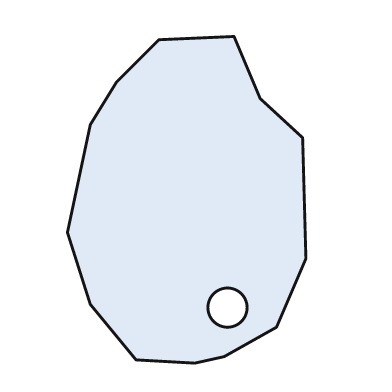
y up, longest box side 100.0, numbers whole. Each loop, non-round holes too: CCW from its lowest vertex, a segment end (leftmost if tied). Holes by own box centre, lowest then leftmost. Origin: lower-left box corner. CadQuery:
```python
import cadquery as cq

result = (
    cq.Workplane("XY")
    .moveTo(39.0, 0.0)
    .lineTo(48.0, 2.0)
    .lineTo(64.0, 11.0)
    .lineTo(73.0, 32.0)
    .lineTo(72.0, 69.0)
    .lineTo(59.0, 81.0)
    .lineTo(51.0, 100.0)
    .lineTo(28.0, 99.0)
    .lineTo(15.0, 86.0)
    .lineTo(7.0, 73.0)
    .lineTo(0.0, 40.0)
    .lineTo(7.0, 18.0)
    .lineTo(21.0, 1.0)
    .close()
    .moveTo(49.0, 17.0)
    .circle(6.0)
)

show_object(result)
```